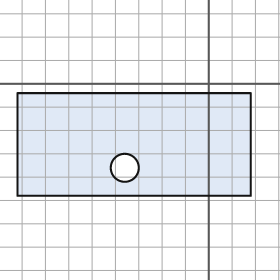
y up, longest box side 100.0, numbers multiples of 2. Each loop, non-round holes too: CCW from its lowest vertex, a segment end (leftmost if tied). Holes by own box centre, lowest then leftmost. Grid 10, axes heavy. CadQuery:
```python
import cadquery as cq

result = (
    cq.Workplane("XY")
    .moveTo(-82.0, -48.0)
    .lineTo(18.0, -48.0)
    .lineTo(18.0, -4.0)
    .lineTo(-82.0, -4.0)
    .close()
    .moveTo(-36.0, -36.0)
    .circle(6.0)
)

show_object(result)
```